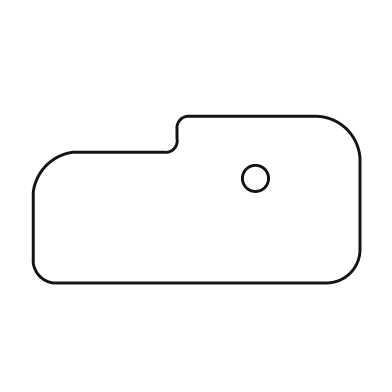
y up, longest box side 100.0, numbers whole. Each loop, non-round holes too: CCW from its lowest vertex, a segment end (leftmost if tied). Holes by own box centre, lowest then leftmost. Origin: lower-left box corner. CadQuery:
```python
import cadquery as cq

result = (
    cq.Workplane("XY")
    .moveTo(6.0, 0.0)
    .lineTo(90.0, 0.0)
    .threePointArc((97.0, 3.0), (100.0, 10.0))
    .lineTo(100.0, 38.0)
    .threePointArc((96.0, 47.0), (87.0, 51.0))
    .lineTo(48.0, 51.0)
    .threePointArc((45.0, 50.0), (44.0, 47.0))
    .lineTo(44.0, 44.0)
    .threePointArc((43.0, 41.0), (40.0, 40.0))
    .lineTo(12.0, 40.0)
    .threePointArc((4.0, 36.0), (0.0, 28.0))
    .lineTo(0.0, 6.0)
    .threePointArc((2.0, 2.0), (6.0, 0.0))
    .close()
    .moveTo(68.0, 32.0)
    .circle(4.0)
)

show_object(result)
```